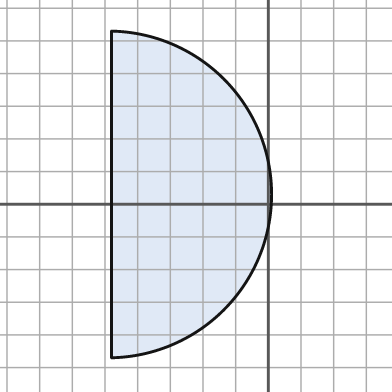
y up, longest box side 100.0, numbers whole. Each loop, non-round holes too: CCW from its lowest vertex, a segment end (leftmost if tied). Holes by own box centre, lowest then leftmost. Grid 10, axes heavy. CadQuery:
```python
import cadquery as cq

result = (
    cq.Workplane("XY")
    .moveTo(-48.0, -47.0)
    .threePointArc((1.0, 3.0), (-48.0, 53.0))
    .close()
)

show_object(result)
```